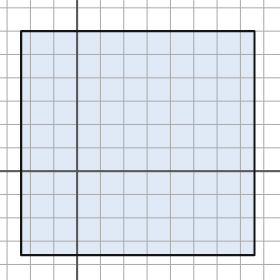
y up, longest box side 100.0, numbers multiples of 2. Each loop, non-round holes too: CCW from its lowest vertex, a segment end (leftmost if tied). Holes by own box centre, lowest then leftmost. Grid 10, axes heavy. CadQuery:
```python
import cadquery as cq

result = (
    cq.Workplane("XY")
    .moveTo(-24.0, -36.0)
    .lineTo(76.0, -36.0)
    .lineTo(76.0, 60.0)
    .lineTo(-24.0, 60.0)
    .close()
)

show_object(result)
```